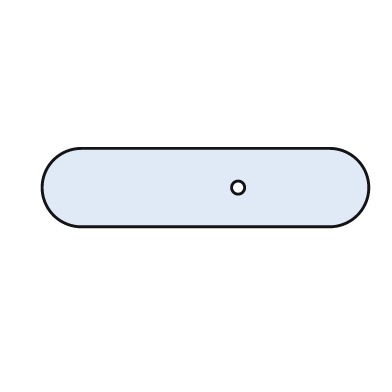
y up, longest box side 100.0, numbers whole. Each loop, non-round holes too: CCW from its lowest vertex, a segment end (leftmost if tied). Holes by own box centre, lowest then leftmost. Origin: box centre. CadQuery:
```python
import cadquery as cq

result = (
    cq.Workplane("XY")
    .moveTo(-38.0, -12.0)
    .lineTo(38.0, -12.0)
    .threePointArc((50.0, 0.0), (38.0, 12.0))
    .lineTo(-38.0, 12.0)
    .threePointArc((-50.0, 0.0), (-38.0, -12.0))
    .close()
    .moveTo(10.0, 0.0)
    .circle(2.0)
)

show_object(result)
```